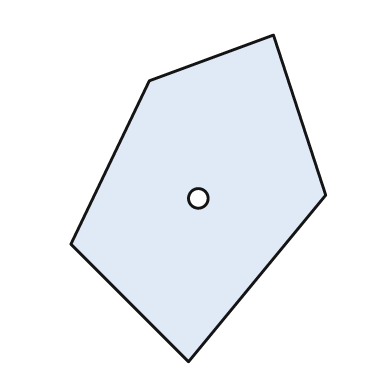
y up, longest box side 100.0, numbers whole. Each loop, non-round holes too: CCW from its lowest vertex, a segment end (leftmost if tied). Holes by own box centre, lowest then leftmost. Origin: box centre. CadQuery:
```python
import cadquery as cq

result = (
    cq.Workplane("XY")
    .moveTo(-3.0, -50.0)
    .lineTo(39.0, 1.0)
    .lineTo(23.0, 50.0)
    .lineTo(-15.0, 36.0)
    .lineTo(-39.0, -14.0)
    .close()
    .moveTo(0.0, 0.0)
    .circle(3.0)
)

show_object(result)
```